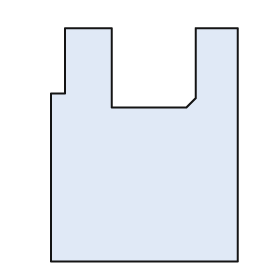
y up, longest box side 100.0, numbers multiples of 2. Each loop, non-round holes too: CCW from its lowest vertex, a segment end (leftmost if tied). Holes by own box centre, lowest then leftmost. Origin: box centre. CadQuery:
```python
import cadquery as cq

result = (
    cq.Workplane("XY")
    .moveTo(-40.0, -50.0)
    .lineTo(40.0, -50.0)
    .lineTo(40.0, 50.0)
    .lineTo(22.0, 50.0)
    .lineTo(22.0, 20.0)
    .lineTo(18.0, 16.0)
    .lineTo(-14.0, 16.0)
    .lineTo(-14.0, 50.0)
    .lineTo(-34.0, 50.0)
    .lineTo(-34.0, 22.0)
    .lineTo(-40.0, 22.0)
    .close()
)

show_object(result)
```